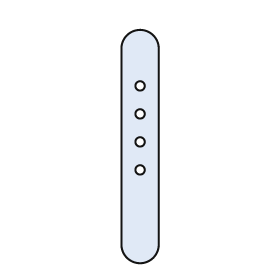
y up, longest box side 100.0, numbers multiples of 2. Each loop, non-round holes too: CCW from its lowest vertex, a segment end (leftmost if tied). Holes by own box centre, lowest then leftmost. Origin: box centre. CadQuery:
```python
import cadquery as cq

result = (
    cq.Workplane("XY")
    .moveTo(-8.0, -42.0)
    .threePointArc((0.0, -50.0), (8.0, -42.0))
    .lineTo(8.0, 42.0)
    .threePointArc((0.0, 50.0), (-8.0, 42.0))
    .close()
    .moveTo(0.0, -10.0)
    .circle(2.0)
    .moveTo(0.0, 2.0)
    .circle(2.0)
    .moveTo(0.0, 14.0)
    .circle(2.0)
    .moveTo(0.0, 26.0)
    .circle(2.0)
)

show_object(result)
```